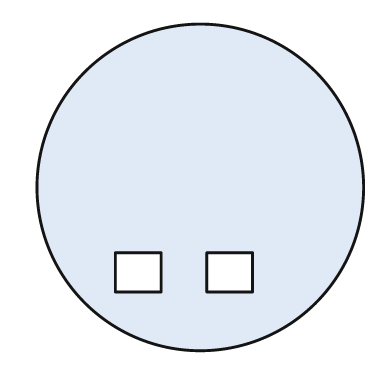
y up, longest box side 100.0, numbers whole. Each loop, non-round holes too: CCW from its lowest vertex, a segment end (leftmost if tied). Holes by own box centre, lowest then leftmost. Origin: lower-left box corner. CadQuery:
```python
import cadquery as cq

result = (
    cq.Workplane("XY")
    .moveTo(50.0, 50.0)
    .circle(50.0)
    .moveTo(24.0, 18.0)
    .lineTo(38.0, 18.0)
    .lineTo(38.0, 30.0)
    .lineTo(24.0, 30.0)
    .close()
    .moveTo(52.0, 18.0)
    .lineTo(66.0, 18.0)
    .lineTo(66.0, 30.0)
    .lineTo(52.0, 30.0)
    .close()
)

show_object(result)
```